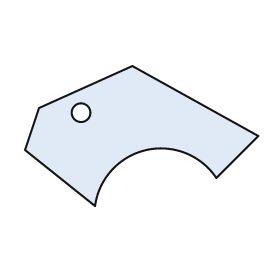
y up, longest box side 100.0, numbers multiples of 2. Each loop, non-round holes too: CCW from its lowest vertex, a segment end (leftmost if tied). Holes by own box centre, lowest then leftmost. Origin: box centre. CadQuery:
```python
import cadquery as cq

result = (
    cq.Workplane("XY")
    .moveTo(-20.0, -30.0)
    .threePointArc((2.0, -6.0), (32.0, -18.0))
    .lineTo(50.0, 0.0)
    .lineTo(-4.0, 30.0)
    .lineTo(-44.0, 12.0)
    .lineTo(-50.0, -6.0)
    .close()
    .moveTo(-26.0, 10.0)
    .circle(4.0)
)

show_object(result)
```